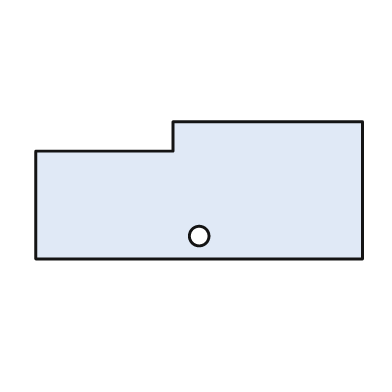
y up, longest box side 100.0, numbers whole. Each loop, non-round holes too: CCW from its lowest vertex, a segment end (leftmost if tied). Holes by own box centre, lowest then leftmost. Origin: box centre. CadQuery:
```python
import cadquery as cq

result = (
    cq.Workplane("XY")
    .moveTo(-50.0, -21.0)
    .lineTo(50.0, -21.0)
    .lineTo(50.0, 21.0)
    .lineTo(-8.0, 21.0)
    .lineTo(-8.0, 12.0)
    .lineTo(-50.0, 12.0)
    .close()
    .moveTo(0.0, -14.0)
    .circle(3.0)
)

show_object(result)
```